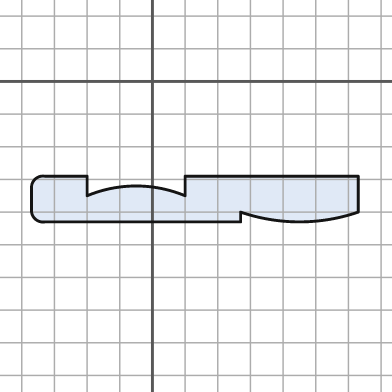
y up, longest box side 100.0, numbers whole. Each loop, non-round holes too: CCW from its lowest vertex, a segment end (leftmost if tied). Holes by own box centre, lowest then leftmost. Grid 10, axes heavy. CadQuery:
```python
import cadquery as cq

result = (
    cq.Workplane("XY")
    .moveTo(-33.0, -43.0)
    .lineTo(27.0, -43.0)
    .lineTo(27.0, -40.0)
    .threePointArc((45.0, -43.0), (63.0, -40.0))
    .lineTo(63.0, -29.0)
    .lineTo(10.0, -29.0)
    .lineTo(10.0, -35.0)
    .threePointArc((-5.0, -32.0), (-20.0, -35.0))
    .lineTo(-20.0, -29.0)
    .lineTo(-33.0, -29.0)
    .threePointArc((-36.0, -30.0), (-37.0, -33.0))
    .lineTo(-37.0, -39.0)
    .threePointArc((-36.0, -42.0), (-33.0, -43.0))
    .close()
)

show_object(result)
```